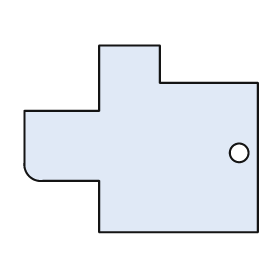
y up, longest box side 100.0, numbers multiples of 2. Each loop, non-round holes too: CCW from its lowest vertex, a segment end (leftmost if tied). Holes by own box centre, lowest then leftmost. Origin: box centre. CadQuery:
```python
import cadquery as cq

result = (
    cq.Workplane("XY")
    .moveTo(-18.0, -40.0)
    .lineTo(50.0, -40.0)
    .lineTo(50.0, 24.0)
    .lineTo(8.0, 24.0)
    .lineTo(8.0, 40.0)
    .lineTo(-18.0, 40.0)
    .lineTo(-18.0, 12.0)
    .lineTo(-50.0, 12.0)
    .lineTo(-50.0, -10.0)
    .threePointArc((-48.0, -16.0), (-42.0, -18.0))
    .lineTo(-18.0, -18.0)
    .close()
    .moveTo(42.0, -6.0)
    .circle(4.0)
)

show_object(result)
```